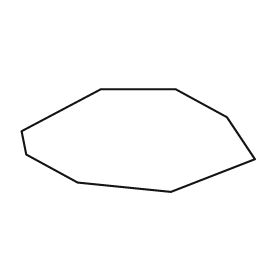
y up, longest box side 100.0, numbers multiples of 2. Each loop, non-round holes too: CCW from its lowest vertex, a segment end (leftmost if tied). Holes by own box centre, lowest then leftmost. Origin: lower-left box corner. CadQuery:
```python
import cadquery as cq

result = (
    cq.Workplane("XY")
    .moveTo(64.0, 0.0)
    .lineTo(100.0, 14.0)
    .lineTo(88.0, 32.0)
    .lineTo(66.0, 44.0)
    .lineTo(34.0, 44.0)
    .lineTo(0.0, 26.0)
    .lineTo(2.0, 16.0)
    .lineTo(24.0, 4.0)
    .close()
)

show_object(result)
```